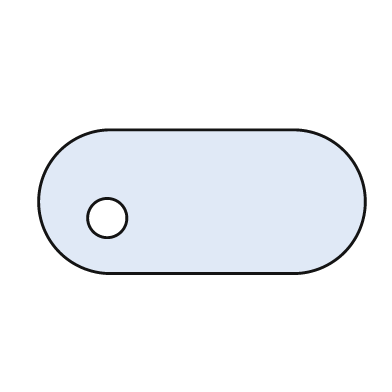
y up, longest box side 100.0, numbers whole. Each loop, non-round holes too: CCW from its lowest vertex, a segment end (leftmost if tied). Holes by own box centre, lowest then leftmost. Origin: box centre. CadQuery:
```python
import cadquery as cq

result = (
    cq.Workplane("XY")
    .moveTo(-28.0, -22.0)
    .lineTo(28.0, -22.0)
    .threePointArc((50.0, 0.0), (28.0, 22.0))
    .lineTo(-28.0, 22.0)
    .threePointArc((-50.0, 0.0), (-28.0, -22.0))
    .close()
    .moveTo(-29.0, -5.0)
    .circle(6.0)
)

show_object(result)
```